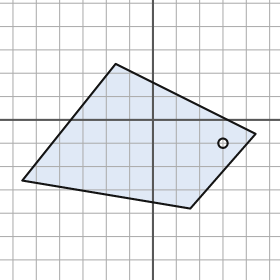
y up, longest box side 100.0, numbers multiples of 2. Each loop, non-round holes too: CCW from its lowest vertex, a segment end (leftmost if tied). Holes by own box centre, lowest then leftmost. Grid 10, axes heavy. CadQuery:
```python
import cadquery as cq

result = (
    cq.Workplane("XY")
    .moveTo(16.0, -38.0)
    .lineTo(44.0, -6.0)
    .lineTo(-16.0, 24.0)
    .lineTo(-56.0, -26.0)
    .close()
    .moveTo(30.0, -10.0)
    .circle(2.0)
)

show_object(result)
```